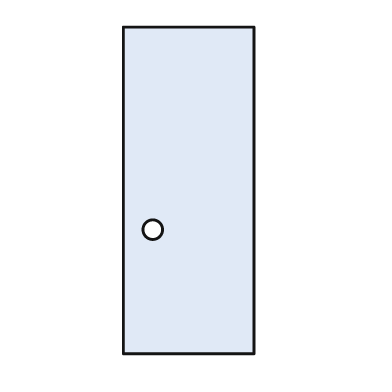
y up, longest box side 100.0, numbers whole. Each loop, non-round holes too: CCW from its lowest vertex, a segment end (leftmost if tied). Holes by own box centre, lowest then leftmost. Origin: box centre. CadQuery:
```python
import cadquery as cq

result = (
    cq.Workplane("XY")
    .moveTo(-20.0, -50.0)
    .lineTo(20.0, -50.0)
    .lineTo(20.0, 50.0)
    .lineTo(-20.0, 50.0)
    .close()
    .moveTo(-11.0, -12.0)
    .circle(3.0)
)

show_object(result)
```